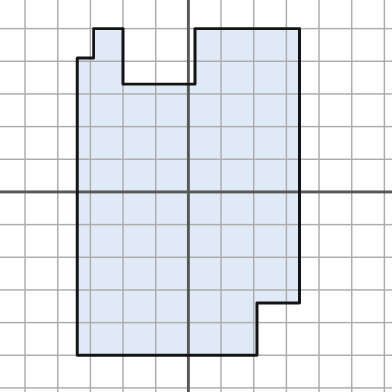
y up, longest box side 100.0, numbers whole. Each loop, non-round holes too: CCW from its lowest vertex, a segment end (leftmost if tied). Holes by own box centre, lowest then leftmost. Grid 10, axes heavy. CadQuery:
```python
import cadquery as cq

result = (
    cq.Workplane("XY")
    .moveTo(-34.0, -50.0)
    .lineTo(21.0, -50.0)
    .lineTo(21.0, -34.0)
    .lineTo(34.0, -34.0)
    .lineTo(34.0, 50.0)
    .lineTo(2.0, 50.0)
    .lineTo(2.0, 33.0)
    .lineTo(-20.0, 33.0)
    .lineTo(-20.0, 50.0)
    .lineTo(-29.0, 50.0)
    .lineTo(-29.0, 41.0)
    .lineTo(-34.0, 41.0)
    .close()
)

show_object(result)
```